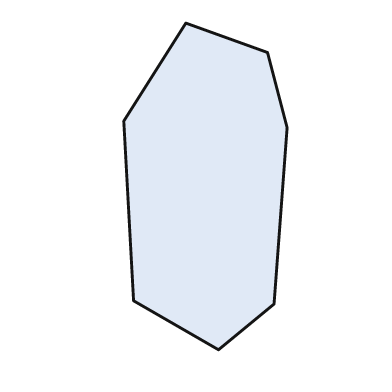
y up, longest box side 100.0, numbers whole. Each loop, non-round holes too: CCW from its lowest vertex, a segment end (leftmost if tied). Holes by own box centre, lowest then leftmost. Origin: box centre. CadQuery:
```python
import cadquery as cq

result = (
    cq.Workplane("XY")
    .moveTo(4.0, -50.0)
    .lineTo(21.0, -36.0)
    .lineTo(25.0, 18.0)
    .lineTo(19.0, 41.0)
    .lineTo(-6.0, 50.0)
    .lineTo(-25.0, 20.0)
    .lineTo(-22.0, -35.0)
    .close()
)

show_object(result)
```